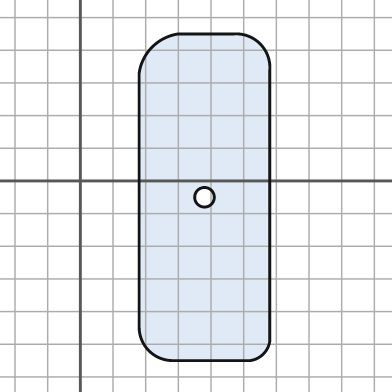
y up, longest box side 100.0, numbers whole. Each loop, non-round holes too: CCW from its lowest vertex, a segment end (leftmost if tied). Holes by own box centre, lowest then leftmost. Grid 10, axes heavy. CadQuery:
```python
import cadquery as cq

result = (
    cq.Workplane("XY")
    .moveTo(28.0, -55.0)
    .lineTo(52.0, -55.0)
    .threePointArc((56.0, -53.0), (58.0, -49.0))
    .lineTo(58.0, 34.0)
    .threePointArc((55.0, 42.0), (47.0, 45.0))
    .lineTo(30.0, 45.0)
    .threePointArc((22.0, 41.0), (18.0, 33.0))
    .lineTo(18.0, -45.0)
    .threePointArc((21.0, -52.0), (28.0, -55.0))
    .close()
    .moveTo(38.0, -5.0)
    .circle(3.0)
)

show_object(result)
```